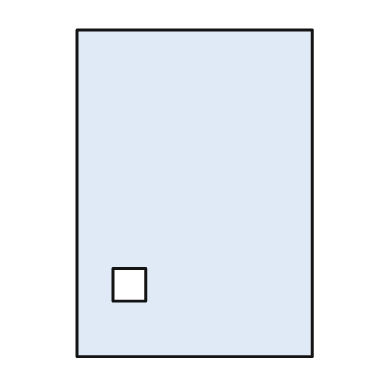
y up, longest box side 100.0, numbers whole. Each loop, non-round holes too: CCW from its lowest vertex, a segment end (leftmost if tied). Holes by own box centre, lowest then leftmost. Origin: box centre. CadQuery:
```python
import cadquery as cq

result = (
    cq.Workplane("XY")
    .moveTo(-36.0, -50.0)
    .lineTo(36.0, -50.0)
    .lineTo(36.0, 50.0)
    .lineTo(-36.0, 50.0)
    .close()
    .moveTo(-25.0, -33.0)
    .lineTo(-15.0, -33.0)
    .lineTo(-15.0, -23.0)
    .lineTo(-25.0, -23.0)
    .close()
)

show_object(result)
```